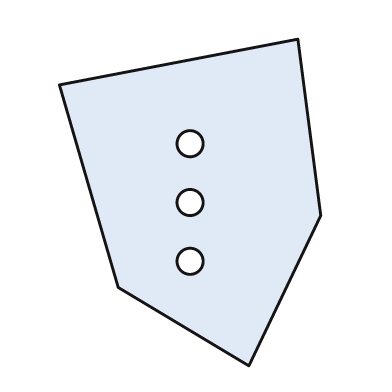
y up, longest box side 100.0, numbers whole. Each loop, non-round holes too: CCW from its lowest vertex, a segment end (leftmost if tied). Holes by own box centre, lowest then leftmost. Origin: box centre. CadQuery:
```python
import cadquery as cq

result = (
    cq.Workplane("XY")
    .moveTo(18.0, -50.0)
    .lineTo(40.0, -4.0)
    .lineTo(33.0, 50.0)
    .lineTo(-40.0, 36.0)
    .lineTo(-22.0, -26.0)
    .close()
    .moveTo(0.0, -18.0)
    .circle(4.0)
    .moveTo(0.0, 0.0)
    .circle(4.0)
    .moveTo(0.0, 18.0)
    .circle(4.0)
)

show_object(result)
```